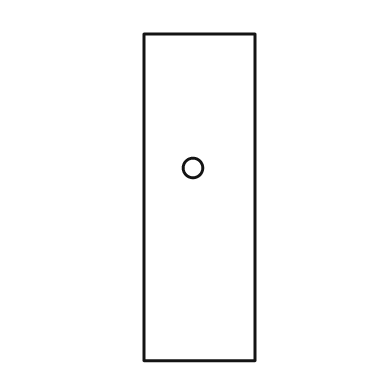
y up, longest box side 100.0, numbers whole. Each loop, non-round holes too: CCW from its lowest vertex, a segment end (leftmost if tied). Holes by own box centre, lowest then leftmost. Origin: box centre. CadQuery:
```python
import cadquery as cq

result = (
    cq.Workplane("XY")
    .moveTo(-17.0, -50.0)
    .lineTo(17.0, -50.0)
    .lineTo(17.0, 50.0)
    .lineTo(-17.0, 50.0)
    .close()
    .moveTo(-2.0, 9.0)
    .circle(3.0)
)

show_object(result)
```